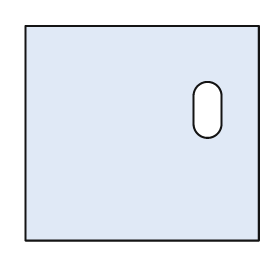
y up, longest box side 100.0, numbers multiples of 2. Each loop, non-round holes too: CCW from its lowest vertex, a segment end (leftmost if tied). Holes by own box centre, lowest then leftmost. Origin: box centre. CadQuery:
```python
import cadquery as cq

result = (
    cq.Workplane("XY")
    .moveTo(-50.0, -46.0)
    .lineTo(50.0, -46.0)
    .lineTo(50.0, 46.0)
    .lineTo(-50.0, 46.0)
    .close()
    .moveTo(22.0, 4.0)
    .threePointArc((28.0, -2.0), (34.0, 4.0))
    .lineTo(34.0, 16.0)
    .threePointArc((28.0, 22.0), (22.0, 16.0))
    .close()
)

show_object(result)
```